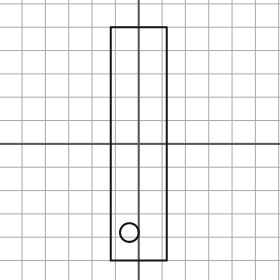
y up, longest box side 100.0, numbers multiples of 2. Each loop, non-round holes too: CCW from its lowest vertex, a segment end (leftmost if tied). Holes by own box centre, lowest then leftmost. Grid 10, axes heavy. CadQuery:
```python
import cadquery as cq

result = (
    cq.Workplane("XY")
    .moveTo(-12.0, -50.0)
    .lineTo(12.0, -50.0)
    .lineTo(12.0, 50.0)
    .lineTo(-12.0, 50.0)
    .close()
    .moveTo(-4.0, -38.0)
    .circle(4.0)
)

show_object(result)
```